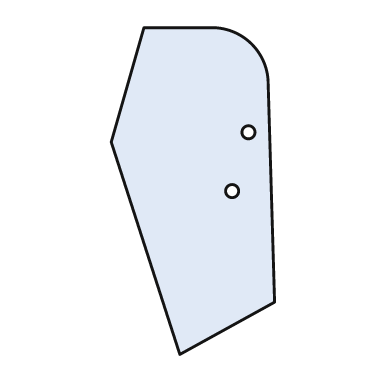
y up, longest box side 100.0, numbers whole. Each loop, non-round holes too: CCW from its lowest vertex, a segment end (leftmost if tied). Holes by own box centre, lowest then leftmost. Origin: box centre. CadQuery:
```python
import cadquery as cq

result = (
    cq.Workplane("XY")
    .moveTo(-4.0, -50.0)
    .lineTo(25.0, -34.0)
    .lineTo(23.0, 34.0)
    .threePointArc((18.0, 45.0), (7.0, 50.0))
    .lineTo(-15.0, 50.0)
    .lineTo(-25.0, 15.0)
    .close()
    .moveTo(12.0, 0.0)
    .circle(2.0)
    .moveTo(17.0, 18.0)
    .circle(2.0)
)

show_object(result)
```